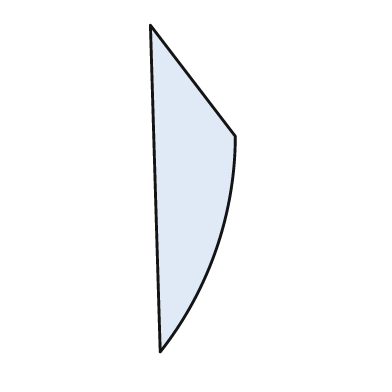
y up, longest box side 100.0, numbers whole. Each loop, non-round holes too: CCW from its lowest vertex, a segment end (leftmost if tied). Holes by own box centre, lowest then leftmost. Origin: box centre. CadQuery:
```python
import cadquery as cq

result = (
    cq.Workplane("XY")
    .moveTo(-10.0, -50.0)
    .threePointArc((7.0, -19.0), (13.0, 16.0))
    .lineTo(-13.0, 50.0)
    .close()
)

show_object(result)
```